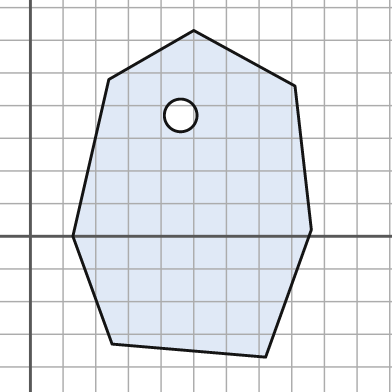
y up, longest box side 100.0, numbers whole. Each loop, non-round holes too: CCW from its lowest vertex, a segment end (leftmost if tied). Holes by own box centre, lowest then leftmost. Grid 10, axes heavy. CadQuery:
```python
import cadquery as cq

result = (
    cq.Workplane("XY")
    .moveTo(72.0, -37.0)
    .lineTo(86.0, 2.0)
    .lineTo(81.0, 46.0)
    .lineTo(50.0, 63.0)
    .lineTo(24.0, 48.0)
    .lineTo(13.0, 0.0)
    .lineTo(25.0, -33.0)
    .close()
    .moveTo(46.0, 37.0)
    .circle(5.0)
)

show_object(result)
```